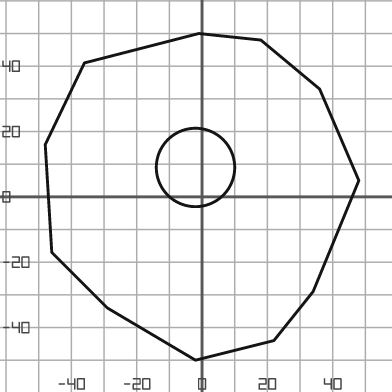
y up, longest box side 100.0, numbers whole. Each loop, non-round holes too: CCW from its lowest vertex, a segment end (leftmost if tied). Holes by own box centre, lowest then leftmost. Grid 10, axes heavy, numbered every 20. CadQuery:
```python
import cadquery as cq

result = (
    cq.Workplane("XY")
    .moveTo(-2.0, -50.0)
    .lineTo(22.0, -44.0)
    .lineTo(34.0, -29.0)
    .lineTo(48.0, 5.0)
    .lineTo(36.0, 33.0)
    .lineTo(18.0, 48.0)
    .lineTo(-1.0, 50.0)
    .lineTo(-36.0, 41.0)
    .lineTo(-48.0, 16.0)
    .lineTo(-46.0, -17.0)
    .lineTo(-29.0, -34.0)
    .close()
    .moveTo(-2.0, 9.0)
    .circle(12.0)
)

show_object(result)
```